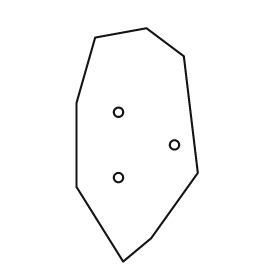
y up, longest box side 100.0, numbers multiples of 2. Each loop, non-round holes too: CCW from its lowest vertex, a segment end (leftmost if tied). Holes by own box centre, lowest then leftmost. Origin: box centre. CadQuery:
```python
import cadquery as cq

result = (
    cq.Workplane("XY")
    .moveTo(-6.0, -50.0)
    .lineTo(6.0, -40.0)
    .lineTo(26.0, -12.0)
    .lineTo(20.0, 38.0)
    .lineTo(4.0, 50.0)
    .lineTo(-18.0, 46.0)
    .lineTo(-26.0, 18.0)
    .lineTo(-26.0, -18.0)
    .close()
    .moveTo(-8.0, -14.0)
    .circle(2.0)
    .moveTo(16.0, 0.0)
    .circle(2.0)
    .moveTo(-8.0, 14.0)
    .circle(2.0)
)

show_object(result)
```